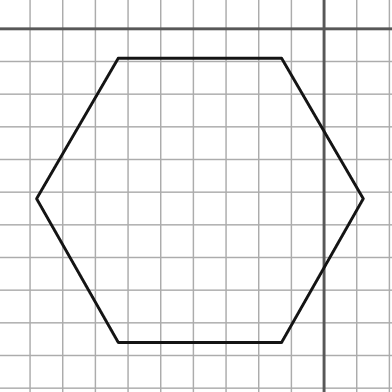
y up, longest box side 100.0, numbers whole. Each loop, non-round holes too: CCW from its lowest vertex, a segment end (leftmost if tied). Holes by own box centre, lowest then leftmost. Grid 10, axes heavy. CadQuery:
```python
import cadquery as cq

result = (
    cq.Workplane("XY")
    .moveTo(-63.0, -96.0)
    .lineTo(-13.0, -96.0)
    .lineTo(12.0, -52.0)
    .lineTo(-13.0, -9.0)
    .lineTo(-63.0, -9.0)
    .lineTo(-88.0, -52.0)
    .close()
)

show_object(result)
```